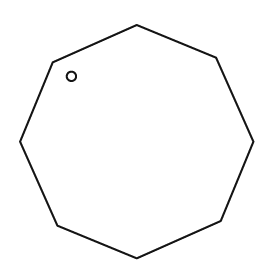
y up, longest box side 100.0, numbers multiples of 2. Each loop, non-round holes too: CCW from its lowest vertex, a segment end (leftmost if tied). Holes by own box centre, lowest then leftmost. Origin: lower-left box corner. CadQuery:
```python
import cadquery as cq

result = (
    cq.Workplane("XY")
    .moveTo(50.0, 0.0)
    .lineTo(86.0, 16.0)
    .lineTo(100.0, 50.0)
    .lineTo(84.0, 86.0)
    .lineTo(50.0, 100.0)
    .lineTo(14.0, 84.0)
    .lineTo(0.0, 50.0)
    .lineTo(16.0, 14.0)
    .close()
    .moveTo(22.0, 78.0)
    .circle(2.0)
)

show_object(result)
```